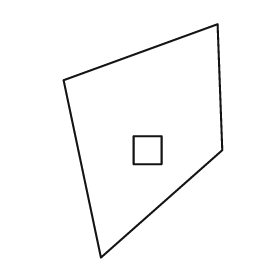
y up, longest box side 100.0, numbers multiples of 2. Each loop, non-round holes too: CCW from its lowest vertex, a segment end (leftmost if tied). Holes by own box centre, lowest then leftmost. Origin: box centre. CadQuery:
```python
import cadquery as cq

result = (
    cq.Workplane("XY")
    .moveTo(-18.0, -50.0)
    .lineTo(34.0, -4.0)
    .lineTo(32.0, 50.0)
    .lineTo(-34.0, 26.0)
    .close()
    .moveTo(-4.0, -10.0)
    .lineTo(8.0, -10.0)
    .lineTo(8.0, 2.0)
    .lineTo(-4.0, 2.0)
    .close()
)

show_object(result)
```